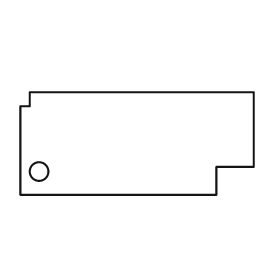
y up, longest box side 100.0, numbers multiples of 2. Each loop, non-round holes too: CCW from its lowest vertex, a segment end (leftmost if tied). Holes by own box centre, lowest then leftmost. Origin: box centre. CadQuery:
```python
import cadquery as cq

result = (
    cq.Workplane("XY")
    .moveTo(-50.0, -22.0)
    .lineTo(34.0, -22.0)
    .lineTo(34.0, -10.0)
    .lineTo(50.0, -10.0)
    .lineTo(50.0, 22.0)
    .lineTo(-46.0, 22.0)
    .lineTo(-46.0, 16.0)
    .lineTo(-50.0, 16.0)
    .close()
    .moveTo(-42.0, -12.0)
    .circle(4.0)
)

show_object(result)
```